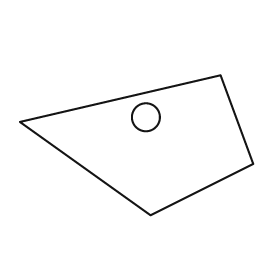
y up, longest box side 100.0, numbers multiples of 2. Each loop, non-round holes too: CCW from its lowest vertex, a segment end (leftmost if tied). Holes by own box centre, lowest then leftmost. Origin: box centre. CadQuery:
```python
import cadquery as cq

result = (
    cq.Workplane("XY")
    .moveTo(6.0, -30.0)
    .lineTo(50.0, -8.0)
    .lineTo(36.0, 30.0)
    .lineTo(-50.0, 10.0)
    .close()
    .moveTo(4.0, 12.0)
    .circle(6.0)
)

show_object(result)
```